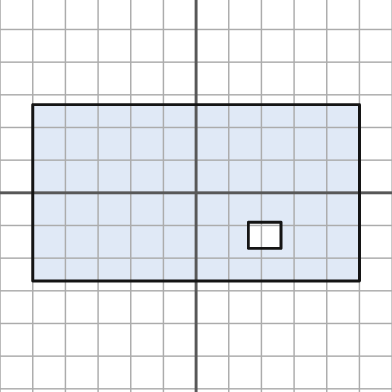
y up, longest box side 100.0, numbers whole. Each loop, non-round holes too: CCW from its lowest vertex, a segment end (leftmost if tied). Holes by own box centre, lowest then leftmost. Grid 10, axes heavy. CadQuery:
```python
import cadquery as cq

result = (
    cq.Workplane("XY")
    .moveTo(-50.0, -27.0)
    .lineTo(50.0, -27.0)
    .lineTo(50.0, 27.0)
    .lineTo(-50.0, 27.0)
    .close()
    .moveTo(16.0, -17.0)
    .lineTo(26.0, -17.0)
    .lineTo(26.0, -9.0)
    .lineTo(16.0, -9.0)
    .close()
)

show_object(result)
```